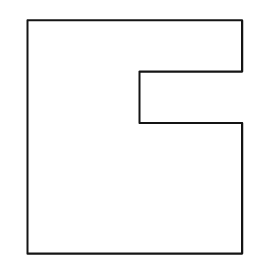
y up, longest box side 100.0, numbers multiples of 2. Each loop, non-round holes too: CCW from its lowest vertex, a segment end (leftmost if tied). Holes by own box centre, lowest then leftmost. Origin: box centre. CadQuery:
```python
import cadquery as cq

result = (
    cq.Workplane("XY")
    .moveTo(-46.0, -50.0)
    .lineTo(46.0, -50.0)
    .lineTo(46.0, 6.0)
    .lineTo(2.0, 6.0)
    .lineTo(2.0, 28.0)
    .lineTo(46.0, 28.0)
    .lineTo(46.0, 50.0)
    .lineTo(-46.0, 50.0)
    .close()
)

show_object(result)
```